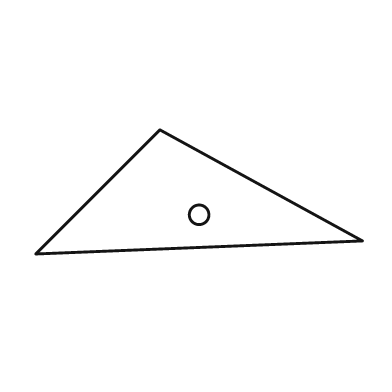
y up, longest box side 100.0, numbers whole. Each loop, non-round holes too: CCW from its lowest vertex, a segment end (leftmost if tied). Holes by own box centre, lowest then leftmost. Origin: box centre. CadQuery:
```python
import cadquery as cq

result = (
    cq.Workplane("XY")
    .moveTo(-50.0, -19.0)
    .lineTo(50.0, -15.0)
    .lineTo(-12.0, 19.0)
    .close()
    .moveTo(0.0, -7.0)
    .circle(3.0)
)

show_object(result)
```